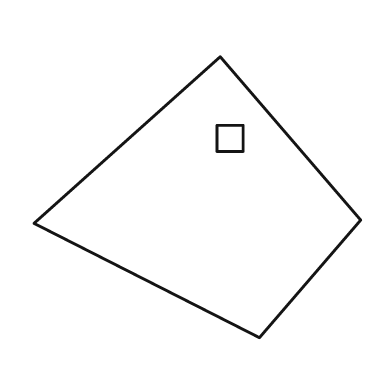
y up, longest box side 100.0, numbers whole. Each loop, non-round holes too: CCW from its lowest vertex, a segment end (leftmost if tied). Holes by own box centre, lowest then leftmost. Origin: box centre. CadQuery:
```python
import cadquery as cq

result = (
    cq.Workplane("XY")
    .moveTo(19.0, -43.0)
    .lineTo(50.0, -7.0)
    .lineTo(7.0, 43.0)
    .lineTo(-50.0, -8.0)
    .close()
    .moveTo(6.0, 14.0)
    .lineTo(14.0, 14.0)
    .lineTo(14.0, 22.0)
    .lineTo(6.0, 22.0)
    .close()
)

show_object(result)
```